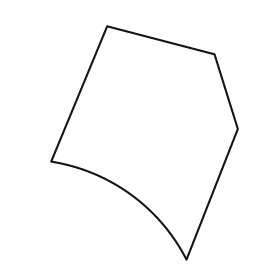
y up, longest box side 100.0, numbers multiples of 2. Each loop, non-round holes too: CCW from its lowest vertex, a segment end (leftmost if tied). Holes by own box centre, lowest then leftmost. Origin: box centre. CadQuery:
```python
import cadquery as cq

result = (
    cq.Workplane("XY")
    .moveTo(18.0, -50.0)
    .lineTo(40.0, 6.0)
    .lineTo(30.0, 38.0)
    .lineTo(-16.0, 50.0)
    .lineTo(-40.0, -8.0)
    .threePointArc((-6.0, -22.0), (18.0, -50.0))
    .close()
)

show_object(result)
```